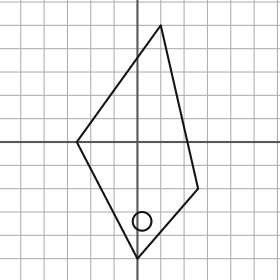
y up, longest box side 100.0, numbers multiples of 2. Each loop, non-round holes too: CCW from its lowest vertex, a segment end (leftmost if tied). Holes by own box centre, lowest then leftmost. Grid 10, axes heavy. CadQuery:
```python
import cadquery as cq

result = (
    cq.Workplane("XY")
    .moveTo(0.0, -50.0)
    .lineTo(26.0, -20.0)
    .lineTo(10.0, 50.0)
    .lineTo(-26.0, 0.0)
    .close()
    .moveTo(2.0, -34.0)
    .circle(4.0)
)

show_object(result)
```